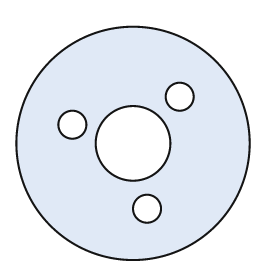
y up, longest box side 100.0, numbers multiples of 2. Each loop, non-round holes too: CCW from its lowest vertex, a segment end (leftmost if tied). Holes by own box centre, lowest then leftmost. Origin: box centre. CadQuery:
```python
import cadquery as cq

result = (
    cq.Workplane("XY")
    .moveTo(0.0, 0.0)
    .circle(50.0)
    .moveTo(6.0, -28.0)
    .circle(6.0)
    .moveTo(0.0, 0.0)
    .circle(16.0)
    .moveTo(-26.0, 8.0)
    .circle(6.0)
    .moveTo(20.0, 20.0)
    .circle(6.0)
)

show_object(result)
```